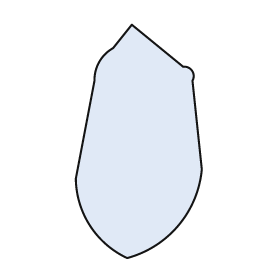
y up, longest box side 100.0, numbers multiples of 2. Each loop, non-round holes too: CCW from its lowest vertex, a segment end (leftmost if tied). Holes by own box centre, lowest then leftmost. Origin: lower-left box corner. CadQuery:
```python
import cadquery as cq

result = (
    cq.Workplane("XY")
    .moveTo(22.0, 0.0)
    .threePointArc((44.0, 14.0), (54.0, 38.0))
    .lineTo(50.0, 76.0)
    .threePointArc((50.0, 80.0), (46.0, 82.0))
    .lineTo(24.0, 100.0)
    .lineTo(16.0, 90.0)
    .threePointArc((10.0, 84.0), (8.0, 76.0))
    .lineTo(0.0, 34.0)
    .threePointArc((6.0, 14.0), (22.0, 0.0))
    .close()
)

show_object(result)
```